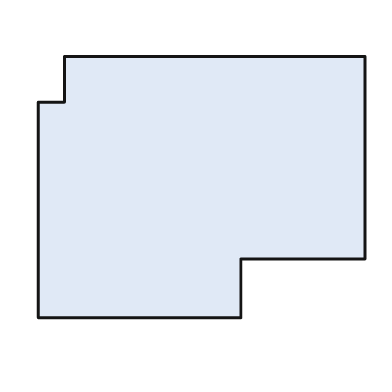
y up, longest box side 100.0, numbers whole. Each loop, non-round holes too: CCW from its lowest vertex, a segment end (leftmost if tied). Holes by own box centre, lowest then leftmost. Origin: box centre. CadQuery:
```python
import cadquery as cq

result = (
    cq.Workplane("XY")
    .moveTo(-50.0, -40.0)
    .lineTo(12.0, -40.0)
    .lineTo(12.0, -22.0)
    .lineTo(50.0, -22.0)
    .lineTo(50.0, 40.0)
    .lineTo(-42.0, 40.0)
    .lineTo(-42.0, 26.0)
    .lineTo(-50.0, 26.0)
    .close()
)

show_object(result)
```